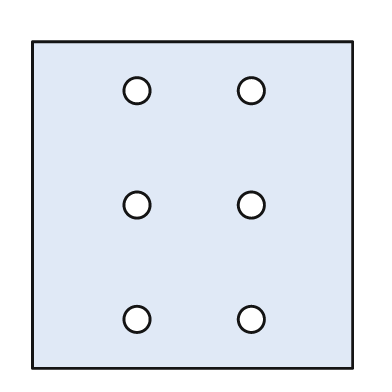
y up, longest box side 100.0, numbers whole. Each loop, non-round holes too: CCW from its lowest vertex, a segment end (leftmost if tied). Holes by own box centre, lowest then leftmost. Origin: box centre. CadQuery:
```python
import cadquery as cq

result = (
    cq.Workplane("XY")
    .moveTo(-49.0, -50.0)
    .lineTo(49.0, -50.0)
    .lineTo(49.0, 50.0)
    .lineTo(-49.0, 50.0)
    .close()
    .moveTo(-17.0, -35.0)
    .circle(4.0)
    .moveTo(18.0, -35.0)
    .circle(4.0)
    .moveTo(-17.0, 0.0)
    .circle(4.0)
    .moveTo(18.0, 0.0)
    .circle(4.0)
    .moveTo(-17.0, 35.0)
    .circle(4.0)
    .moveTo(18.0, 35.0)
    .circle(4.0)
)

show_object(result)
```